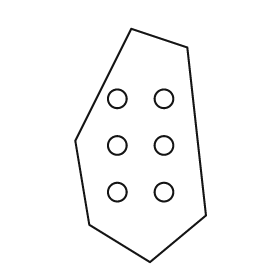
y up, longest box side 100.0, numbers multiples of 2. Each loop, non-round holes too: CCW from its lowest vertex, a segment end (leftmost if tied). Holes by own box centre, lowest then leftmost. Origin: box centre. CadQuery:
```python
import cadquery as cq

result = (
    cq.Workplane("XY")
    .moveTo(4.0, -50.0)
    .lineTo(28.0, -30.0)
    .lineTo(20.0, 42.0)
    .lineTo(-4.0, 50.0)
    .lineTo(-28.0, 2.0)
    .lineTo(-22.0, -34.0)
    .close()
    .moveTo(-10.0, -20.0)
    .circle(4.0)
    .moveTo(10.0, -20.0)
    .circle(4.0)
    .moveTo(-10.0, 0.0)
    .circle(4.0)
    .moveTo(10.0, 0.0)
    .circle(4.0)
    .moveTo(-10.0, 20.0)
    .circle(4.0)
    .moveTo(10.0, 20.0)
    .circle(4.0)
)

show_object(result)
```